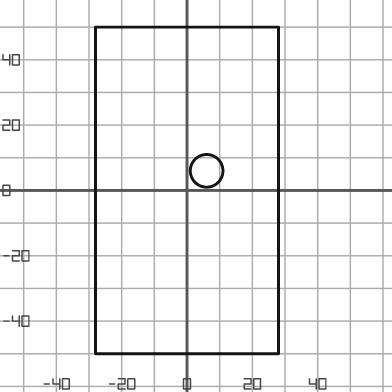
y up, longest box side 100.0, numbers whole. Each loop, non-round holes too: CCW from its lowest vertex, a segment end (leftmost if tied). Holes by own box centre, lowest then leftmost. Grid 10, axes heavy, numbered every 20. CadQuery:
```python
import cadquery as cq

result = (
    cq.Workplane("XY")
    .moveTo(-28.0, -50.0)
    .lineTo(28.0, -50.0)
    .lineTo(28.0, 50.0)
    .lineTo(-28.0, 50.0)
    .close()
    .moveTo(6.0, 6.0)
    .circle(5.0)
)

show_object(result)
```